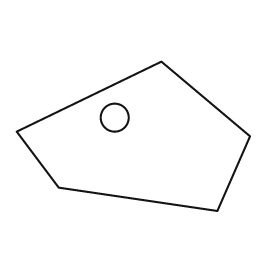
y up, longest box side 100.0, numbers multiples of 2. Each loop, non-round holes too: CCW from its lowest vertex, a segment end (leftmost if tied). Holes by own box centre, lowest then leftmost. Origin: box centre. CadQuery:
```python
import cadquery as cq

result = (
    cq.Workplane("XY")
    .moveTo(36.0, -32.0)
    .lineTo(50.0, 0.0)
    .lineTo(12.0, 32.0)
    .lineTo(-50.0, 2.0)
    .lineTo(-32.0, -22.0)
    .close()
    .moveTo(-8.0, 8.0)
    .circle(6.0)
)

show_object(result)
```